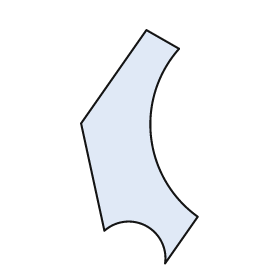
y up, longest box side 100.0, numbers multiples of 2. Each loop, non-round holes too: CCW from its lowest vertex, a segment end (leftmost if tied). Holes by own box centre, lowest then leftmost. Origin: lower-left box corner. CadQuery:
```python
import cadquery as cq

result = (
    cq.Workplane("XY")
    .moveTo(36.0, 0.0)
    .lineTo(50.0, 20.0)
    .threePointArc((30.0, 54.0), (42.0, 92.0))
    .lineTo(28.0, 100.0)
    .lineTo(0.0, 60.0)
    .lineTo(10.0, 14.0)
    .threePointArc((28.0, 16.0), (36.0, 0.0))
    .close()
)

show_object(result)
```